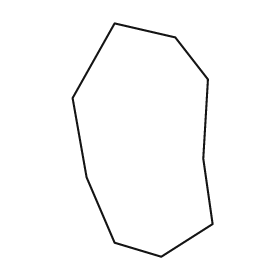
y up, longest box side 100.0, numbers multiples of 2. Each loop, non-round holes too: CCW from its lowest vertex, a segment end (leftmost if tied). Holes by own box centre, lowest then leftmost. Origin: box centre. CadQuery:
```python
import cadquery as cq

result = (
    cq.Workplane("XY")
    .moveTo(8.0, -50.0)
    .lineTo(30.0, -36.0)
    .lineTo(26.0, -8.0)
    .lineTo(28.0, 26.0)
    .lineTo(14.0, 44.0)
    .lineTo(-12.0, 50.0)
    .lineTo(-30.0, 18.0)
    .lineTo(-24.0, -16.0)
    .lineTo(-12.0, -44.0)
    .close()
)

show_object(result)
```